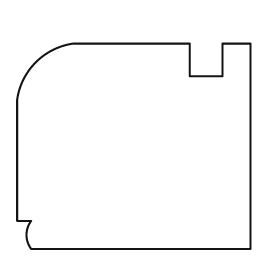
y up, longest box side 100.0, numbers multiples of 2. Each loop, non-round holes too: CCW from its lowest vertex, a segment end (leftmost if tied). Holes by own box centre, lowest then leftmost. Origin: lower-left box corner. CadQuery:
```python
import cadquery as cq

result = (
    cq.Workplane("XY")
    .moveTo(6.0, 0.0)
    .lineTo(100.0, 0.0)
    .lineTo(100.0, 88.0)
    .lineTo(88.0, 88.0)
    .lineTo(88.0, 74.0)
    .lineTo(74.0, 74.0)
    .lineTo(74.0, 88.0)
    .lineTo(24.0, 88.0)
    .threePointArc((8.0, 80.0), (0.0, 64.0))
    .lineTo(0.0, 12.0)
    .lineTo(6.0, 12.0)
    .threePointArc((4.0, 6.0), (6.0, 0.0))
    .close()
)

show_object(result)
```